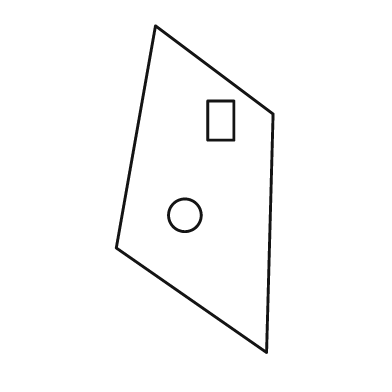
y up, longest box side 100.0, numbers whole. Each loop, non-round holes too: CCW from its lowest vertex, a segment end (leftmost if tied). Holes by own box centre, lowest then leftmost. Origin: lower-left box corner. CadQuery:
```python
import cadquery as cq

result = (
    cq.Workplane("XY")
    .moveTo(46.0, 0.0)
    .lineTo(48.0, 73.0)
    .lineTo(12.0, 100.0)
    .lineTo(0.0, 32.0)
    .close()
    .moveTo(21.0, 42.0)
    .circle(5.0)
    .moveTo(28.0, 65.0)
    .lineTo(36.0, 65.0)
    .lineTo(36.0, 77.0)
    .lineTo(28.0, 77.0)
    .close()
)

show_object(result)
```